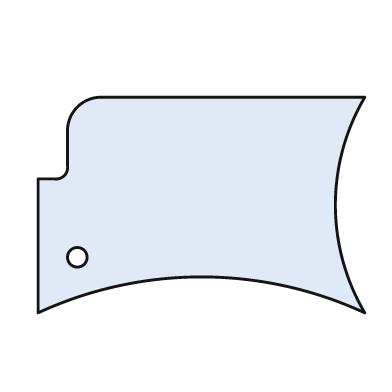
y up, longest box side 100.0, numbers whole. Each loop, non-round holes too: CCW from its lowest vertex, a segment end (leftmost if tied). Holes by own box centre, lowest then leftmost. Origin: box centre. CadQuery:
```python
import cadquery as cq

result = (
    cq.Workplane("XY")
    .moveTo(-50.0, -33.0)
    .threePointArc((0.0, -22.0), (50.0, -33.0))
    .threePointArc((41.0, 0.0), (50.0, 33.0))
    .lineTo(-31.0, 33.0)
    .threePointArc((-38.0, 30.0), (-41.0, 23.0))
    .lineTo(-41.0, 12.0)
    .threePointArc((-42.0, 9.0), (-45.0, 8.0))
    .lineTo(-50.0, 8.0)
    .close()
    .moveTo(-38.0, -16.0)
    .circle(3.0)
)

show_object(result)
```